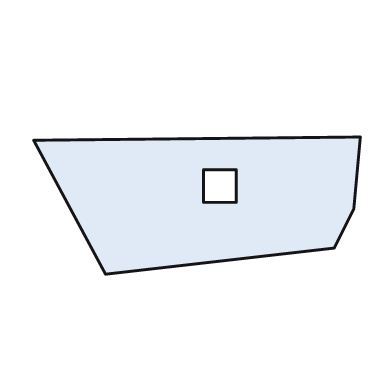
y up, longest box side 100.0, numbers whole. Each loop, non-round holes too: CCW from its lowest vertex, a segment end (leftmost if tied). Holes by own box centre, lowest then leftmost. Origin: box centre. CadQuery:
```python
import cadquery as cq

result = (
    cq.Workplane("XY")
    .moveTo(-28.0, -21.0)
    .lineTo(42.0, -13.0)
    .lineTo(48.0, -1.0)
    .lineTo(50.0, 21.0)
    .lineTo(-50.0, 20.0)
    .close()
    .moveTo(2.0, 1.0)
    .lineTo(12.0, 1.0)
    .lineTo(12.0, 11.0)
    .lineTo(2.0, 11.0)
    .close()
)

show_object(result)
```